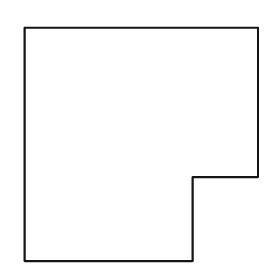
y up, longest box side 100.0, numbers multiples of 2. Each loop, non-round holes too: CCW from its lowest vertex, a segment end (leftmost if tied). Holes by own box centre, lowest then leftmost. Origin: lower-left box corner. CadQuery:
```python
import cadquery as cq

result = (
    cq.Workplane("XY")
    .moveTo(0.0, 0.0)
    .lineTo(72.0, 0.0)
    .lineTo(72.0, 36.0)
    .lineTo(100.0, 36.0)
    .lineTo(100.0, 100.0)
    .lineTo(0.0, 100.0)
    .close()
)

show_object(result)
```